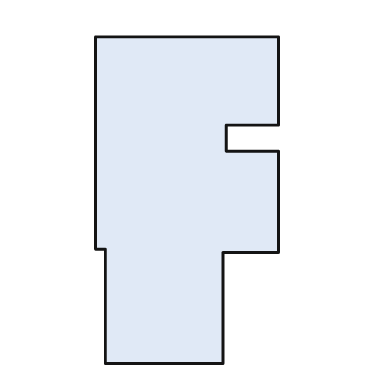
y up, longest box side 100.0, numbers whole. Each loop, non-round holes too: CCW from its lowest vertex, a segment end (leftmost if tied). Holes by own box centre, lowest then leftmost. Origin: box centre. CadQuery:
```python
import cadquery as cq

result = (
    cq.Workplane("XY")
    .moveTo(-25.0, -50.0)
    .lineTo(11.0, -50.0)
    .lineTo(11.0, -16.0)
    .lineTo(28.0, -16.0)
    .lineTo(28.0, 15.0)
    .lineTo(12.0, 15.0)
    .lineTo(12.0, 23.0)
    .lineTo(28.0, 23.0)
    .lineTo(28.0, 50.0)
    .lineTo(-28.0, 50.0)
    .lineTo(-28.0, -15.0)
    .lineTo(-25.0, -15.0)
    .close()
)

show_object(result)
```